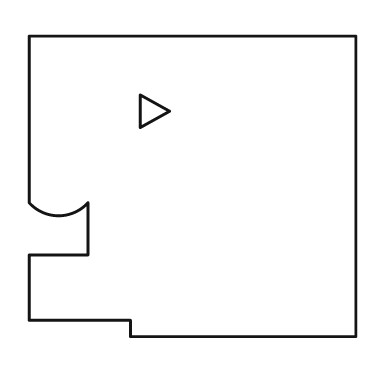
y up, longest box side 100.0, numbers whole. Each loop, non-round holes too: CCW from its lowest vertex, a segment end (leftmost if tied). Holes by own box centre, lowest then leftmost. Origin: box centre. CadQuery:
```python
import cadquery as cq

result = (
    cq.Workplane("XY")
    .moveTo(-19.0, -46.0)
    .lineTo(50.0, -46.0)
    .lineTo(50.0, 46.0)
    .lineTo(-50.0, 46.0)
    .lineTo(-50.0, -5.0)
    .threePointArc((-41.0, -9.0), (-32.0, -5.0))
    .lineTo(-32.0, -21.0)
    .lineTo(-50.0, -21.0)
    .lineTo(-50.0, -41.0)
    .lineTo(-19.0, -41.0)
    .close()
    .moveTo(-16.0, 18.0)
    .lineTo(-7.0, 23.0)
    .lineTo(-16.0, 28.0)
    .close()
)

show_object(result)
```